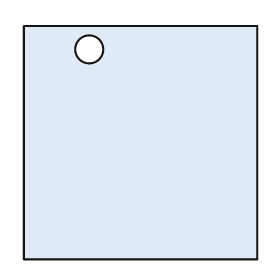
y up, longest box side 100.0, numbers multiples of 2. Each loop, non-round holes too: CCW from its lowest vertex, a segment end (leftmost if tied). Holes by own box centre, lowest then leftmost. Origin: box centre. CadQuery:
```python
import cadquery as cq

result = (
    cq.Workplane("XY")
    .moveTo(-50.0, -50.0)
    .lineTo(50.0, -50.0)
    .lineTo(50.0, 50.0)
    .lineTo(-50.0, 50.0)
    .close()
    .moveTo(-22.0, 40.0)
    .circle(6.0)
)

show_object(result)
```